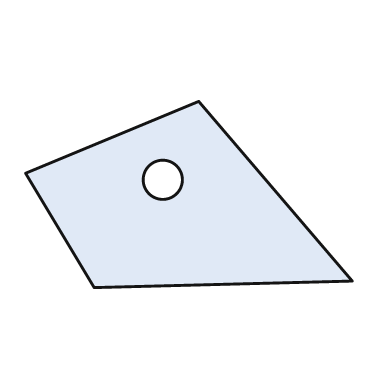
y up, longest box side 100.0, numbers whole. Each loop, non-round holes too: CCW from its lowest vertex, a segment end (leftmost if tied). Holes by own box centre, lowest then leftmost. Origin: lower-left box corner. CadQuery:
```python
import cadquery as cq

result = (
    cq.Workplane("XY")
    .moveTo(21.0, 0.0)
    .lineTo(100.0, 2.0)
    .lineTo(53.0, 57.0)
    .lineTo(0.0, 35.0)
    .close()
    .moveTo(42.0, 33.0)
    .circle(6.0)
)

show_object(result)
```